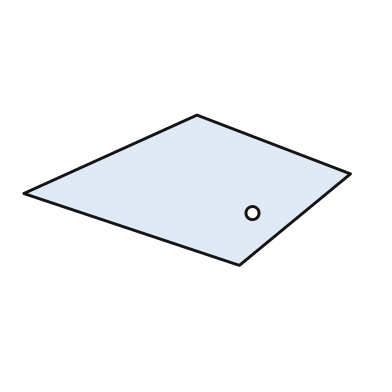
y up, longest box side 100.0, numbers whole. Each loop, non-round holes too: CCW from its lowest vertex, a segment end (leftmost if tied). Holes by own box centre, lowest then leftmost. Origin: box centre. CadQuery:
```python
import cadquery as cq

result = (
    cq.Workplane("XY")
    .moveTo(16.0, -23.0)
    .lineTo(50.0, 5.0)
    .lineTo(3.0, 23.0)
    .lineTo(-50.0, -1.0)
    .close()
    .moveTo(20.0, -7.0)
    .circle(2.0)
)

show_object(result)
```